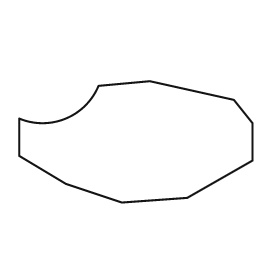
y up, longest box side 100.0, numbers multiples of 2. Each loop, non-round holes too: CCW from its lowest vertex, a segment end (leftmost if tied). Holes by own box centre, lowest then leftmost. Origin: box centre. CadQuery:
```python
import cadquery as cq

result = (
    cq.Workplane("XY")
    .moveTo(-6.0, -26.0)
    .lineTo(22.0, -24.0)
    .lineTo(50.0, -8.0)
    .lineTo(50.0, 8.0)
    .lineTo(42.0, 18.0)
    .lineTo(6.0, 26.0)
    .lineTo(-16.0, 24.0)
    .threePointArc((-30.0, 10.0), (-50.0, 10.0))
    .lineTo(-50.0, -6.0)
    .lineTo(-30.0, -18.0)
    .close()
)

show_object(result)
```